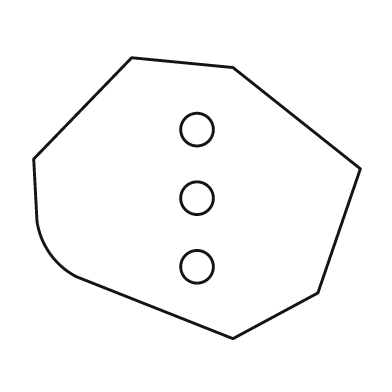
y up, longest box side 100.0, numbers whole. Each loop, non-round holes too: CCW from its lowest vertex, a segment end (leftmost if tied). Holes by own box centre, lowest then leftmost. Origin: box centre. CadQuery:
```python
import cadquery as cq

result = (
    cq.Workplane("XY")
    .moveTo(11.0, -43.0)
    .lineTo(37.0, -29.0)
    .lineTo(50.0, 9.0)
    .lineTo(11.0, 40.0)
    .lineTo(-20.0, 43.0)
    .lineTo(-50.0, 12.0)
    .lineTo(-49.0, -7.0)
    .threePointArc((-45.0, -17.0), (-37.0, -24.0))
    .close()
    .moveTo(0.0, -21.0)
    .circle(5.0)
    .moveTo(0.0, 0.0)
    .circle(5.0)
    .moveTo(0.0, 21.0)
    .circle(5.0)
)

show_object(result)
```